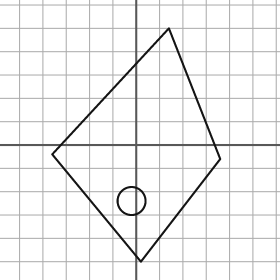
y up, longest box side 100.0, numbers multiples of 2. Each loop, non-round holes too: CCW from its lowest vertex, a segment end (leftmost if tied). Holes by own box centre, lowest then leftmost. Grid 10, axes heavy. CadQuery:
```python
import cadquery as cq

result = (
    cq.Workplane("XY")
    .moveTo(2.0, -50.0)
    .lineTo(36.0, -6.0)
    .lineTo(14.0, 50.0)
    .lineTo(-36.0, -4.0)
    .close()
    .moveTo(-2.0, -24.0)
    .circle(6.0)
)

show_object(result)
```